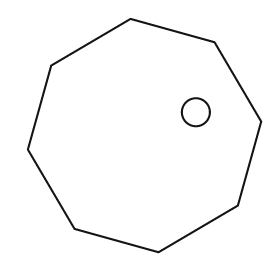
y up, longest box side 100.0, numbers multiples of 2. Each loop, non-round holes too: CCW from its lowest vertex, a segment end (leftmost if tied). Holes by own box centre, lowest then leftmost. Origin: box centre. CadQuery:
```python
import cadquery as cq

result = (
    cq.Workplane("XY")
    .moveTo(6.0, -50.0)
    .lineTo(40.0, -30.0)
    .lineTo(50.0, 6.0)
    .lineTo(30.0, 40.0)
    .lineTo(-6.0, 50.0)
    .lineTo(-40.0, 30.0)
    .lineTo(-50.0, -6.0)
    .lineTo(-30.0, -40.0)
    .close()
    .moveTo(22.0, 10.0)
    .circle(6.0)
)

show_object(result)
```